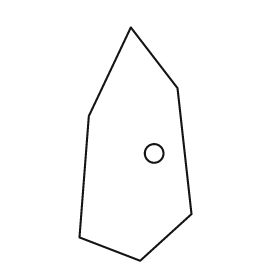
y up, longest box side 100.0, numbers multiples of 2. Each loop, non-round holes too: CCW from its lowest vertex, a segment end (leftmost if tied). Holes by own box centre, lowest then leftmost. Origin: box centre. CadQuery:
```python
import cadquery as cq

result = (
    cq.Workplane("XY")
    .moveTo(2.0, -50.0)
    .lineTo(24.0, -30.0)
    .lineTo(18.0, 24.0)
    .lineTo(-2.0, 50.0)
    .lineTo(-20.0, 12.0)
    .lineTo(-24.0, -40.0)
    .close()
    .moveTo(8.0, -4.0)
    .circle(4.0)
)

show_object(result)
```